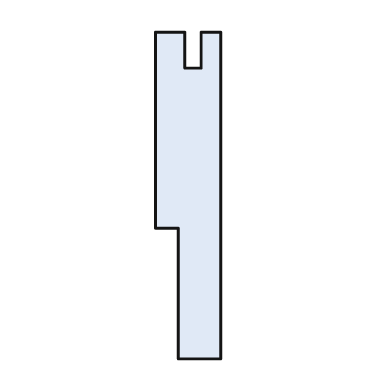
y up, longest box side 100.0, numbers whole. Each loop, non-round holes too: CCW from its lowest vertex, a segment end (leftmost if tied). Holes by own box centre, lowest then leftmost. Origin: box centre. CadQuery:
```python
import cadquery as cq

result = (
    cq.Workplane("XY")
    .moveTo(-3.0, -50.0)
    .lineTo(10.0, -50.0)
    .lineTo(10.0, 50.0)
    .lineTo(4.0, 50.0)
    .lineTo(4.0, 39.0)
    .lineTo(-1.0, 39.0)
    .lineTo(-1.0, 50.0)
    .lineTo(-10.0, 50.0)
    .lineTo(-10.0, -10.0)
    .lineTo(-3.0, -10.0)
    .close()
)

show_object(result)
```